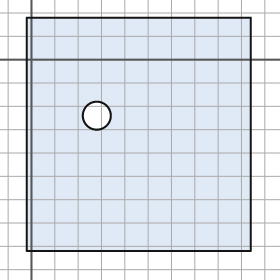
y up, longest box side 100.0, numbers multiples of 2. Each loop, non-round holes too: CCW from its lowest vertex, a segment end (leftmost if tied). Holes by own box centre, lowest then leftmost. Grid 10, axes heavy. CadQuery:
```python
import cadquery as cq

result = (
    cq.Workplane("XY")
    .moveTo(-2.0, -82.0)
    .lineTo(94.0, -82.0)
    .lineTo(94.0, 18.0)
    .lineTo(-2.0, 18.0)
    .close()
    .moveTo(28.0, -24.0)
    .circle(6.0)
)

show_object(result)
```